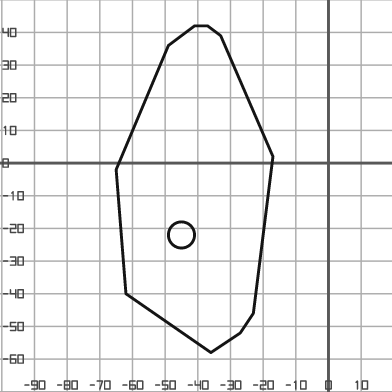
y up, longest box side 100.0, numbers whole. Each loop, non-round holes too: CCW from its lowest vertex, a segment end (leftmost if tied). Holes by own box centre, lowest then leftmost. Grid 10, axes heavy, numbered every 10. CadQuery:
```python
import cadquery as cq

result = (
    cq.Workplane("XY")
    .moveTo(-36.0, -58.0)
    .lineTo(-27.0, -52.0)
    .lineTo(-23.0, -46.0)
    .lineTo(-17.0, 2.0)
    .lineTo(-33.0, 39.0)
    .lineTo(-37.0, 42.0)
    .lineTo(-41.0, 42.0)
    .lineTo(-49.0, 36.0)
    .lineTo(-65.0, -2.0)
    .lineTo(-62.0, -40.0)
    .close()
    .moveTo(-45.0, -22.0)
    .circle(4.0)
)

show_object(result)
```